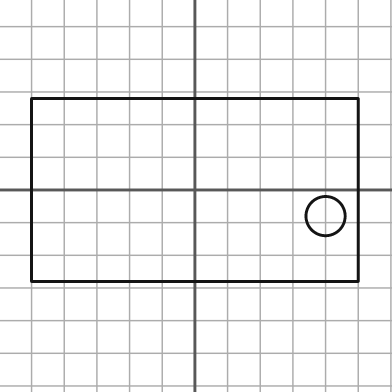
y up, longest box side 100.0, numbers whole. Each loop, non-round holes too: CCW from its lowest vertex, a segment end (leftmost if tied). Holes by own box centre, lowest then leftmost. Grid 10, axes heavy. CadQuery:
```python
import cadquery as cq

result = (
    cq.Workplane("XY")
    .moveTo(-50.0, -28.0)
    .lineTo(50.0, -28.0)
    .lineTo(50.0, 28.0)
    .lineTo(-50.0, 28.0)
    .close()
    .moveTo(40.0, -8.0)
    .circle(6.0)
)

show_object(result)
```